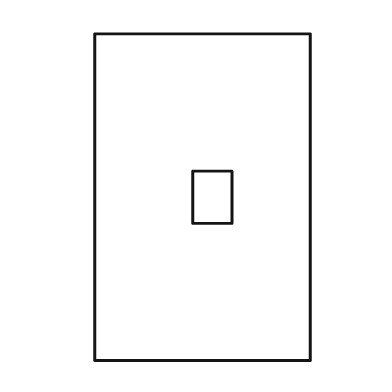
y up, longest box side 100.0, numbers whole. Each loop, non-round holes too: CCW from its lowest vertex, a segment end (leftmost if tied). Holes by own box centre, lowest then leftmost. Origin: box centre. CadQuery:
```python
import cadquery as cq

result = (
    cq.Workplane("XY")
    .moveTo(-33.0, -50.0)
    .lineTo(33.0, -50.0)
    .lineTo(33.0, 50.0)
    .lineTo(-33.0, 50.0)
    .close()
    .moveTo(-3.0, -8.0)
    .lineTo(9.0, -8.0)
    .lineTo(9.0, 8.0)
    .lineTo(-3.0, 8.0)
    .close()
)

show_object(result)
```